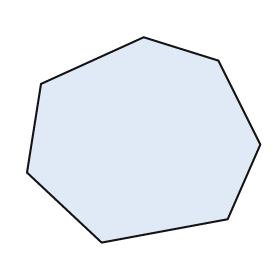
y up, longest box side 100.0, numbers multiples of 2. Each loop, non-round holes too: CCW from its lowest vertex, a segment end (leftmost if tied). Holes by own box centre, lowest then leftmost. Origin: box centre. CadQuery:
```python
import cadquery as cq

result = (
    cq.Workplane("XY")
    .moveTo(-18.0, -44.0)
    .lineTo(36.0, -34.0)
    .lineTo(50.0, -2.0)
    .lineTo(32.0, 34.0)
    .lineTo(0.0, 44.0)
    .lineTo(-44.0, 24.0)
    .lineTo(-50.0, -14.0)
    .close()
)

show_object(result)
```